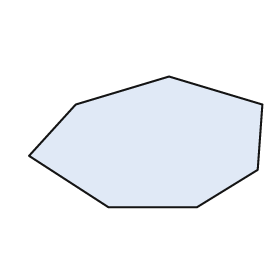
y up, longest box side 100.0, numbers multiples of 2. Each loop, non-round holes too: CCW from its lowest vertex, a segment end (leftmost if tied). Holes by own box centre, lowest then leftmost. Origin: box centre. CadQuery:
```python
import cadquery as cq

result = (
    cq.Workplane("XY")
    .moveTo(-16.0, -28.0)
    .lineTo(22.0, -28.0)
    .lineTo(48.0, -12.0)
    .lineTo(50.0, 16.0)
    .lineTo(10.0, 28.0)
    .lineTo(-30.0, 16.0)
    .lineTo(-50.0, -6.0)
    .close()
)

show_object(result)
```